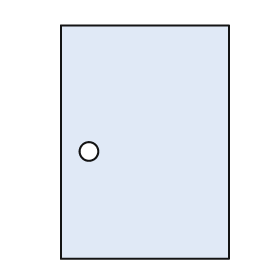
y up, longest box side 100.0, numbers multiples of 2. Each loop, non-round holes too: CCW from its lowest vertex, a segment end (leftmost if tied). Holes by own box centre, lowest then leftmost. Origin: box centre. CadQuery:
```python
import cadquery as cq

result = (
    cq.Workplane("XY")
    .moveTo(-36.0, -50.0)
    .lineTo(36.0, -50.0)
    .lineTo(36.0, 50.0)
    .lineTo(-36.0, 50.0)
    .close()
    .moveTo(-24.0, -4.0)
    .circle(4.0)
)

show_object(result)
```